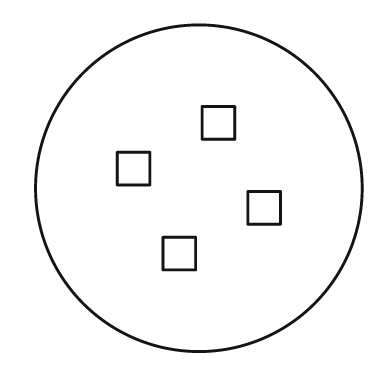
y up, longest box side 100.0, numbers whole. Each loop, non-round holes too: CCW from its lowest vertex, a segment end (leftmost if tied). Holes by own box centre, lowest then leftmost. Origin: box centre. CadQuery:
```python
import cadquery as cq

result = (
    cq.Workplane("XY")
    .moveTo(0.0, 0.0)
    .circle(50.0)
    .moveTo(-11.0, -25.0)
    .lineTo(-1.0, -25.0)
    .lineTo(-1.0, -15.0)
    .lineTo(-11.0, -15.0)
    .close()
    .moveTo(15.0, -11.0)
    .lineTo(25.0, -11.0)
    .lineTo(25.0, -1.0)
    .lineTo(15.0, -1.0)
    .close()
    .moveTo(-25.0, 1.0)
    .lineTo(-15.0, 1.0)
    .lineTo(-15.0, 11.0)
    .lineTo(-25.0, 11.0)
    .close()
    .moveTo(1.0, 15.0)
    .lineTo(11.0, 15.0)
    .lineTo(11.0, 25.0)
    .lineTo(1.0, 25.0)
    .close()
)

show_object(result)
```